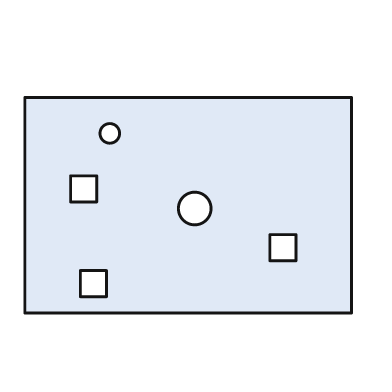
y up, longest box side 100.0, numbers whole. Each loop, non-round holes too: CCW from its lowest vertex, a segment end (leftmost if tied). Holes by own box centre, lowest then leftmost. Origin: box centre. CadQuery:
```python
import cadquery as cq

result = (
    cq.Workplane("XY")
    .moveTo(-50.0, -33.0)
    .lineTo(50.0, -33.0)
    .lineTo(50.0, 33.0)
    .lineTo(-50.0, 33.0)
    .close()
    .moveTo(-33.0, -28.0)
    .lineTo(-25.0, -28.0)
    .lineTo(-25.0, -20.0)
    .lineTo(-33.0, -20.0)
    .close()
    .moveTo(25.0, -17.0)
    .lineTo(33.0, -17.0)
    .lineTo(33.0, -9.0)
    .lineTo(25.0, -9.0)
    .close()
    .moveTo(2.0, -1.0)
    .circle(5.0)
    .moveTo(-36.0, 1.0)
    .lineTo(-28.0, 1.0)
    .lineTo(-28.0, 9.0)
    .lineTo(-36.0, 9.0)
    .close()
    .moveTo(-24.0, 22.0)
    .circle(3.0)
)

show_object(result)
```